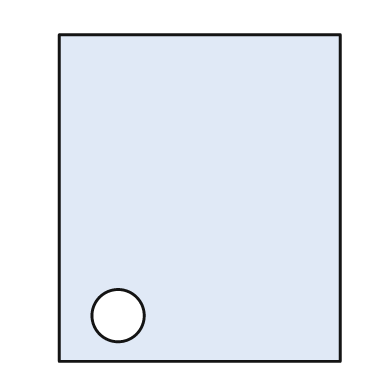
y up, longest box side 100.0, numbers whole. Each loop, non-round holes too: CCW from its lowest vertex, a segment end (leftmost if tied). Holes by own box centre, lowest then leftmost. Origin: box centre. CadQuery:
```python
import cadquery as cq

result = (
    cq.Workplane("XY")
    .moveTo(-43.0, -50.0)
    .lineTo(43.0, -50.0)
    .lineTo(43.0, 50.0)
    .lineTo(-43.0, 50.0)
    .close()
    .moveTo(-25.0, -36.0)
    .circle(8.0)
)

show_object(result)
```